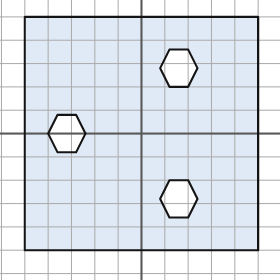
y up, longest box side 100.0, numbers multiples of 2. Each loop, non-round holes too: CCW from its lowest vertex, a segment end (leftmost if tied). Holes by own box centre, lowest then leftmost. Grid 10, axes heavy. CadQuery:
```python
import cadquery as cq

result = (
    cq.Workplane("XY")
    .moveTo(-50.0, -50.0)
    .lineTo(50.0, -50.0)
    .lineTo(50.0, 50.0)
    .lineTo(-50.0, 50.0)
    .close()
    .moveTo(12.0, -36.0)
    .lineTo(20.0, -36.0)
    .lineTo(24.0, -28.0)
    .lineTo(20.0, -20.0)
    .lineTo(12.0, -20.0)
    .lineTo(8.0, -28.0)
    .close()
    .moveTo(-36.0, -8.0)
    .lineTo(-28.0, -8.0)
    .lineTo(-24.0, 0.0)
    .lineTo(-28.0, 8.0)
    .lineTo(-36.0, 8.0)
    .lineTo(-40.0, 0.0)
    .close()
    .moveTo(12.0, 20.0)
    .lineTo(20.0, 20.0)
    .lineTo(24.0, 28.0)
    .lineTo(20.0, 36.0)
    .lineTo(12.0, 36.0)
    .lineTo(8.0, 28.0)
    .close()
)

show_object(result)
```